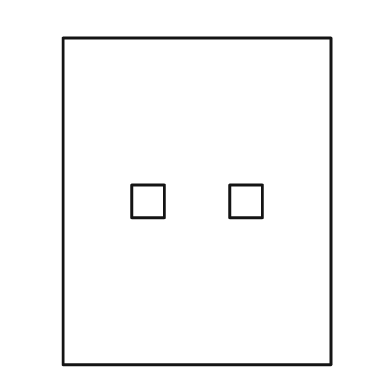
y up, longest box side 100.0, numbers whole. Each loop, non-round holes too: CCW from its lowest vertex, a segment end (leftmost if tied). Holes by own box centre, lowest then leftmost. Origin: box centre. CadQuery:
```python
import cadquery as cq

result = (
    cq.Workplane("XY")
    .moveTo(-41.0, -50.0)
    .lineTo(41.0, -50.0)
    .lineTo(41.0, 50.0)
    .lineTo(-41.0, 50.0)
    .close()
    .moveTo(-20.0, -5.0)
    .lineTo(-10.0, -5.0)
    .lineTo(-10.0, 5.0)
    .lineTo(-20.0, 5.0)
    .close()
    .moveTo(10.0, -5.0)
    .lineTo(20.0, -5.0)
    .lineTo(20.0, 5.0)
    .lineTo(10.0, 5.0)
    .close()
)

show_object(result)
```